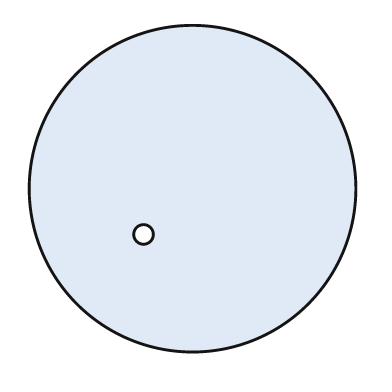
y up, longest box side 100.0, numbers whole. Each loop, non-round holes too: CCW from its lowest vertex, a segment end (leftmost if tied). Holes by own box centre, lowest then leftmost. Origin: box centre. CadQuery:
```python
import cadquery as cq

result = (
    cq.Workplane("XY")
    .moveTo(0.0, 0.0)
    .circle(50.0)
    .moveTo(-15.0, -14.0)
    .circle(3.0)
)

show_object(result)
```